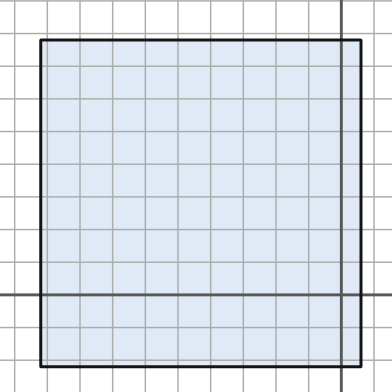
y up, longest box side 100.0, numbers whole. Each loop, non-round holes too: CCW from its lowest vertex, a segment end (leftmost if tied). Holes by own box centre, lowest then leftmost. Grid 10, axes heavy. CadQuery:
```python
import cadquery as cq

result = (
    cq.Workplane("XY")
    .moveTo(-92.0, -22.0)
    .lineTo(6.0, -22.0)
    .lineTo(6.0, 78.0)
    .lineTo(-92.0, 78.0)
    .close()
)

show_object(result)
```